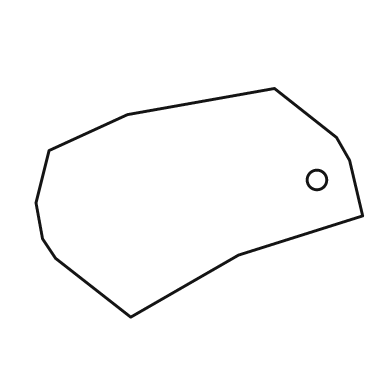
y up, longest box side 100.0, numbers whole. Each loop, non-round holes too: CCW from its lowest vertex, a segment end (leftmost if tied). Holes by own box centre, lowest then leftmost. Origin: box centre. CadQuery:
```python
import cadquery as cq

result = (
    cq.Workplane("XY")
    .moveTo(-21.0, -35.0)
    .lineTo(12.0, -16.0)
    .lineTo(50.0, -4.0)
    .lineTo(46.0, 13.0)
    .lineTo(42.0, 20.0)
    .lineTo(23.0, 35.0)
    .lineTo(-22.0, 27.0)
    .lineTo(-46.0, 16.0)
    .lineTo(-50.0, 0.0)
    .lineTo(-48.0, -11.0)
    .lineTo(-44.0, -17.0)
    .close()
    .moveTo(36.0, 7.0)
    .circle(3.0)
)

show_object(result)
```